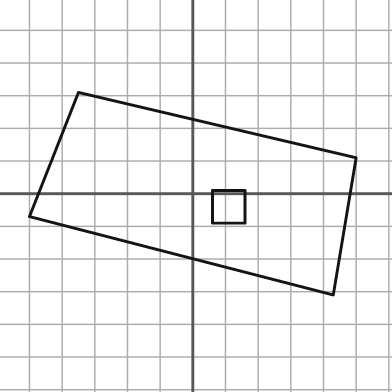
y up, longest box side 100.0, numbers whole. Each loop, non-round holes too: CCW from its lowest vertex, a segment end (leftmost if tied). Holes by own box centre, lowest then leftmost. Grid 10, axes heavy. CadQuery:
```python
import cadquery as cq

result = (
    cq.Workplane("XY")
    .moveTo(43.0, -31.0)
    .lineTo(50.0, 11.0)
    .lineTo(-35.0, 31.0)
    .lineTo(-50.0, -7.0)
    .close()
    .moveTo(6.0, -9.0)
    .lineTo(16.0, -9.0)
    .lineTo(16.0, 1.0)
    .lineTo(6.0, 1.0)
    .close()
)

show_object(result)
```